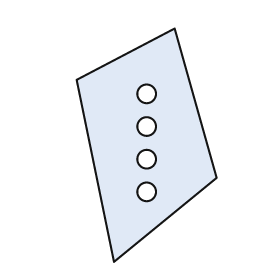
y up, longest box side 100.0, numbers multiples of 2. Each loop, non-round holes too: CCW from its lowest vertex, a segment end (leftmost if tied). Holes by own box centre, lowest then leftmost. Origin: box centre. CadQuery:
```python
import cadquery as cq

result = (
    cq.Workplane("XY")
    .moveTo(-14.0, -50.0)
    .lineTo(30.0, -14.0)
    .lineTo(12.0, 50.0)
    .lineTo(-30.0, 28.0)
    .close()
    .moveTo(0.0, -20.0)
    .circle(4.0)
    .moveTo(0.0, -6.0)
    .circle(4.0)
    .moveTo(0.0, 8.0)
    .circle(4.0)
    .moveTo(0.0, 22.0)
    .circle(4.0)
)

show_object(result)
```